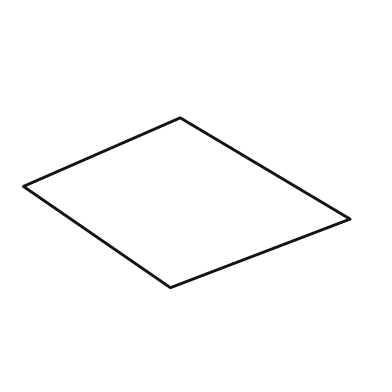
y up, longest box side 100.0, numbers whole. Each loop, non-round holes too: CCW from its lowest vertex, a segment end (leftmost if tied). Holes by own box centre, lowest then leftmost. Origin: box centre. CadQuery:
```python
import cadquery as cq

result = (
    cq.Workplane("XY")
    .moveTo(-5.0, -26.0)
    .lineTo(50.0, -5.0)
    .lineTo(-2.0, 26.0)
    .lineTo(-50.0, 5.0)
    .close()
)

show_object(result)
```